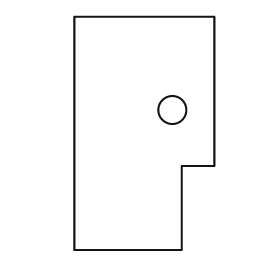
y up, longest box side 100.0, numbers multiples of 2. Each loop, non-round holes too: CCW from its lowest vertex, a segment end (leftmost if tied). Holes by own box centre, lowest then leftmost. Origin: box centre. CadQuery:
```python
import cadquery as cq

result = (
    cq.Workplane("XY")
    .moveTo(-30.0, -50.0)
    .lineTo(16.0, -50.0)
    .lineTo(16.0, -14.0)
    .lineTo(30.0, -14.0)
    .lineTo(30.0, 50.0)
    .lineTo(-30.0, 50.0)
    .close()
    .moveTo(12.0, 10.0)
    .circle(6.0)
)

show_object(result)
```